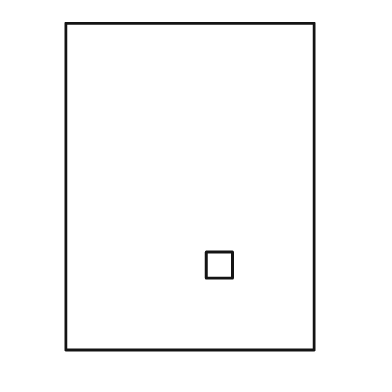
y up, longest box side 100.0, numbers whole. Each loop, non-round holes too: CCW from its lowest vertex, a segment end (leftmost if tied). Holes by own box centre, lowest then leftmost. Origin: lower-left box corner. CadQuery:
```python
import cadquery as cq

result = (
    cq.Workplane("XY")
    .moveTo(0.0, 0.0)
    .lineTo(76.0, 0.0)
    .lineTo(76.0, 100.0)
    .lineTo(0.0, 100.0)
    .close()
    .moveTo(43.0, 22.0)
    .lineTo(51.0, 22.0)
    .lineTo(51.0, 30.0)
    .lineTo(43.0, 30.0)
    .close()
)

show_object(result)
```